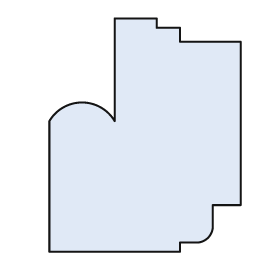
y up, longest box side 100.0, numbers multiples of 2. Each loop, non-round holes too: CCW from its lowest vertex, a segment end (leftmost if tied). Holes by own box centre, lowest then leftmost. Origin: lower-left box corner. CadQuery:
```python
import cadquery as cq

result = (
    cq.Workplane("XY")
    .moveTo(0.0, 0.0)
    .lineTo(56.0, 0.0)
    .lineTo(56.0, 4.0)
    .lineTo(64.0, 4.0)
    .threePointArc((68.0, 6.0), (70.0, 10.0))
    .lineTo(70.0, 20.0)
    .lineTo(82.0, 20.0)
    .lineTo(82.0, 90.0)
    .lineTo(56.0, 90.0)
    .lineTo(56.0, 96.0)
    .lineTo(46.0, 96.0)
    .lineTo(46.0, 100.0)
    .lineTo(28.0, 100.0)
    .lineTo(28.0, 56.0)
    .threePointArc((14.0, 64.0), (0.0, 56.0))
    .close()
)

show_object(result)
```